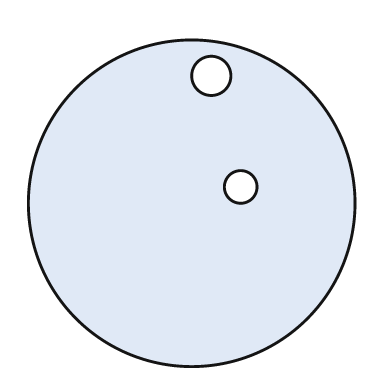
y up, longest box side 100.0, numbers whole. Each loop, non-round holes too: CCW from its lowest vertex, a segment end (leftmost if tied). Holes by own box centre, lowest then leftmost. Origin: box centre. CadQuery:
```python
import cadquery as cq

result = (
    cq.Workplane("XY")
    .moveTo(0.0, 0.0)
    .circle(50.0)
    .moveTo(15.0, 5.0)
    .circle(5.0)
    .moveTo(6.0, 39.0)
    .circle(6.0)
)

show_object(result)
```